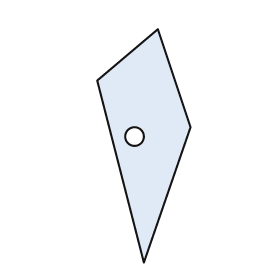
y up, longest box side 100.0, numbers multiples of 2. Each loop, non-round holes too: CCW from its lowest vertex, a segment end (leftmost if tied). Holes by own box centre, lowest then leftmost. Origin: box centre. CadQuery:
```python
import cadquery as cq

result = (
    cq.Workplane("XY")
    .moveTo(0.0, -50.0)
    .lineTo(20.0, 8.0)
    .lineTo(6.0, 50.0)
    .lineTo(-20.0, 28.0)
    .close()
    .moveTo(-4.0, 4.0)
    .circle(4.0)
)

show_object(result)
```